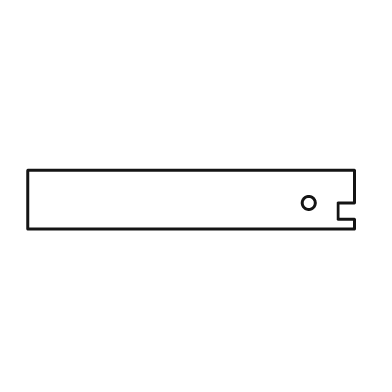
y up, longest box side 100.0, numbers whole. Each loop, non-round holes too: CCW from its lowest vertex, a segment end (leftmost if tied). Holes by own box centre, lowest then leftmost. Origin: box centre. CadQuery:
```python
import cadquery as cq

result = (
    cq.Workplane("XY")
    .moveTo(-50.0, -9.0)
    .lineTo(50.0, -9.0)
    .lineTo(50.0, -6.0)
    .lineTo(45.0, -6.0)
    .lineTo(45.0, -1.0)
    .lineTo(50.0, -1.0)
    .lineTo(50.0, 9.0)
    .lineTo(-50.0, 9.0)
    .close()
    .moveTo(36.0, -1.0)
    .circle(2.0)
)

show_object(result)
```